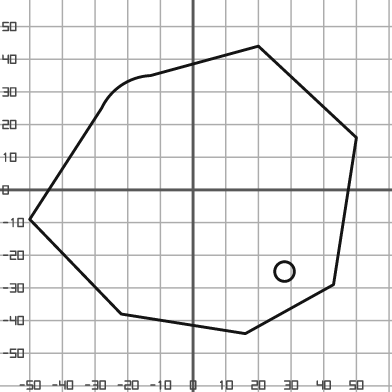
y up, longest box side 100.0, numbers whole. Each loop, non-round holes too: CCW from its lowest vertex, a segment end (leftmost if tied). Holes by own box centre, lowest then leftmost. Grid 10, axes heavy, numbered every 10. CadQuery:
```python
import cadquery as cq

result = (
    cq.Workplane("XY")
    .moveTo(16.0, -44.0)
    .lineTo(43.0, -29.0)
    .lineTo(50.0, 16.0)
    .lineTo(20.0, 44.0)
    .lineTo(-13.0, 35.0)
    .threePointArc((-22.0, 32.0), (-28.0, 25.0))
    .lineTo(-50.0, -9.0)
    .lineTo(-22.0, -38.0)
    .close()
    .moveTo(28.0, -25.0)
    .circle(3.0)
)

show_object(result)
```